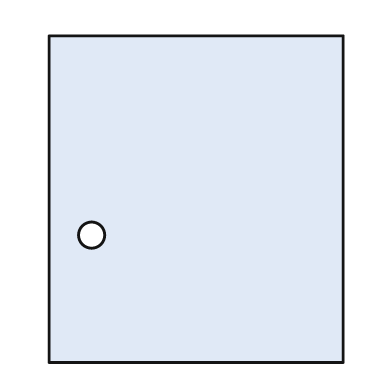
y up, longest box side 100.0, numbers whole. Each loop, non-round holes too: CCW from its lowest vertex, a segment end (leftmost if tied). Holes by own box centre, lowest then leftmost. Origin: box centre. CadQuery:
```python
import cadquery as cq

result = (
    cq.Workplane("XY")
    .moveTo(-45.0, -50.0)
    .lineTo(45.0, -50.0)
    .lineTo(45.0, 50.0)
    .lineTo(-45.0, 50.0)
    .close()
    .moveTo(-32.0, -11.0)
    .circle(4.0)
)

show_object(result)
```